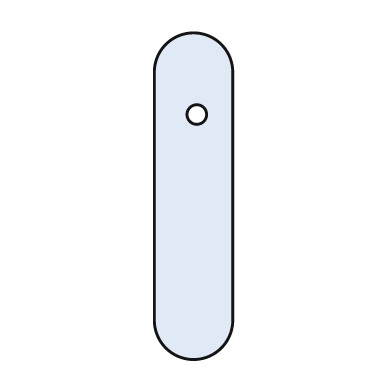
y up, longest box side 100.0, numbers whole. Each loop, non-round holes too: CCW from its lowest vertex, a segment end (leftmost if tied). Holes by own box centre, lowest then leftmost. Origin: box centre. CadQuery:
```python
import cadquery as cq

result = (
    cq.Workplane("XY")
    .moveTo(-12.0, -38.0)
    .threePointArc((0.0, -50.0), (12.0, -38.0))
    .lineTo(12.0, 38.0)
    .threePointArc((0.0, 50.0), (-12.0, 38.0))
    .close()
    .moveTo(1.0, 25.0)
    .circle(3.0)
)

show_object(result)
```